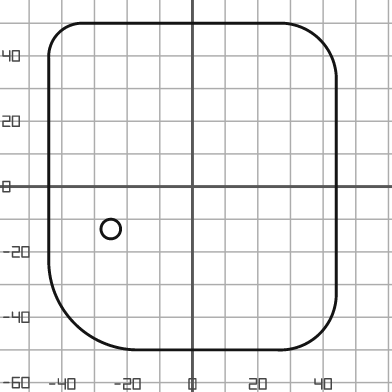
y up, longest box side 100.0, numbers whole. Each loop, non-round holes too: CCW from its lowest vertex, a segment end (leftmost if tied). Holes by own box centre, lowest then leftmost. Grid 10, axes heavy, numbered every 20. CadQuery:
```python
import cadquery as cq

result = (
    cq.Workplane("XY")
    .moveTo(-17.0, -50.0)
    .lineTo(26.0, -50.0)
    .threePointArc((39.0, -45.0), (44.0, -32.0))
    .lineTo(44.0, 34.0)
    .threePointArc((39.0, 45.0), (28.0, 50.0))
    .lineTo(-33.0, 50.0)
    .threePointArc((-41.0, 47.0), (-44.0, 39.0))
    .lineTo(-44.0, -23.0)
    .threePointArc((-36.0, -42.0), (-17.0, -50.0))
    .close()
    .moveTo(-25.0, -13.0)
    .circle(3.0)
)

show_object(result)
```